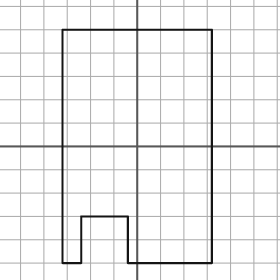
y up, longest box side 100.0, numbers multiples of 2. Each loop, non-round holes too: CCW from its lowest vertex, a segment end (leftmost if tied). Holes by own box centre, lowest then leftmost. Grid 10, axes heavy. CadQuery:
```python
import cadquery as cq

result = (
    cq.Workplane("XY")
    .moveTo(-32.0, -50.0)
    .lineTo(-24.0, -50.0)
    .lineTo(-24.0, -30.0)
    .lineTo(-4.0, -30.0)
    .lineTo(-4.0, -50.0)
    .lineTo(32.0, -50.0)
    .lineTo(32.0, 50.0)
    .lineTo(-32.0, 50.0)
    .close()
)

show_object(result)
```